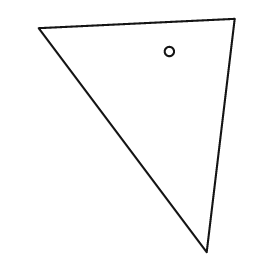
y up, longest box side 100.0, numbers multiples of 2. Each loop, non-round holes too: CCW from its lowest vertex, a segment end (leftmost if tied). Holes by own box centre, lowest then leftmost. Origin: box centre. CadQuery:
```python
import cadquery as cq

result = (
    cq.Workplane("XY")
    .moveTo(30.0, -50.0)
    .lineTo(42.0, 50.0)
    .lineTo(-42.0, 46.0)
    .close()
    .moveTo(14.0, 36.0)
    .circle(2.0)
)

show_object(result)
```